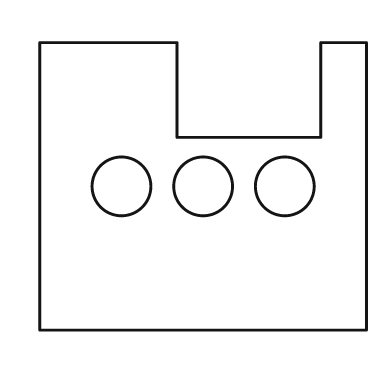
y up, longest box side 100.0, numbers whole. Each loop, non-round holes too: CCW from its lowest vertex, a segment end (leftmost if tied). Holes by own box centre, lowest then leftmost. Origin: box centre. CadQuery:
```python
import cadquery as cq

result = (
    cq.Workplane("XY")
    .moveTo(-50.0, -44.0)
    .lineTo(50.0, -44.0)
    .lineTo(50.0, 44.0)
    .lineTo(36.0, 44.0)
    .lineTo(36.0, 15.0)
    .lineTo(-8.0, 15.0)
    .lineTo(-8.0, 44.0)
    .lineTo(-50.0, 44.0)
    .close()
    .moveTo(-25.0, 0.0)
    .circle(9.0)
    .moveTo(0.0, 0.0)
    .circle(9.0)
    .moveTo(25.0, 0.0)
    .circle(9.0)
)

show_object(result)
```